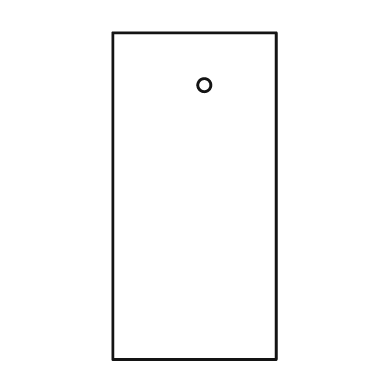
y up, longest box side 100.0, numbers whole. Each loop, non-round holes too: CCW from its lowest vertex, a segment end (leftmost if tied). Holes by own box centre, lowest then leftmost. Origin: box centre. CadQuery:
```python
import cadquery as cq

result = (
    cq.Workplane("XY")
    .moveTo(-25.0, -50.0)
    .lineTo(25.0, -50.0)
    .lineTo(25.0, 50.0)
    .lineTo(-25.0, 50.0)
    .close()
    .moveTo(3.0, 34.0)
    .circle(2.0)
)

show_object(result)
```